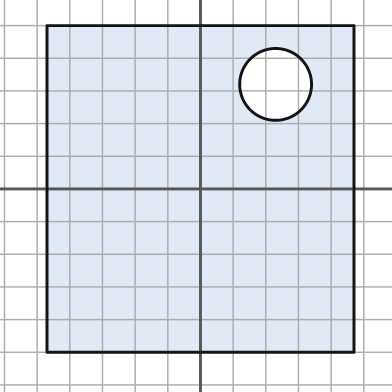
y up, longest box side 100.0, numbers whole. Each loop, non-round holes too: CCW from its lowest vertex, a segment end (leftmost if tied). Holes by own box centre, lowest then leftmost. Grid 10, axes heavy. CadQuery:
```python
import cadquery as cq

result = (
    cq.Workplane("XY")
    .moveTo(-47.0, -50.0)
    .lineTo(47.0, -50.0)
    .lineTo(47.0, 50.0)
    .lineTo(-47.0, 50.0)
    .close()
    .moveTo(23.0, 32.0)
    .circle(11.0)
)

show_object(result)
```